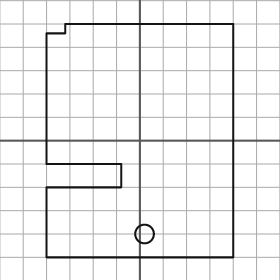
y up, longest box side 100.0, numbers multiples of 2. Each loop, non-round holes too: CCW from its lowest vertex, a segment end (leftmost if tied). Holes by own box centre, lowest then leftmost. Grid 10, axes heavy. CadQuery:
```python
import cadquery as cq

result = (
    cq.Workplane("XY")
    .moveTo(-40.0, -50.0)
    .lineTo(40.0, -50.0)
    .lineTo(40.0, 50.0)
    .lineTo(-32.0, 50.0)
    .lineTo(-32.0, 46.0)
    .lineTo(-40.0, 46.0)
    .lineTo(-40.0, -10.0)
    .lineTo(-8.0, -10.0)
    .lineTo(-8.0, -20.0)
    .lineTo(-40.0, -20.0)
    .close()
    .moveTo(2.0, -40.0)
    .circle(4.0)
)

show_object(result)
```